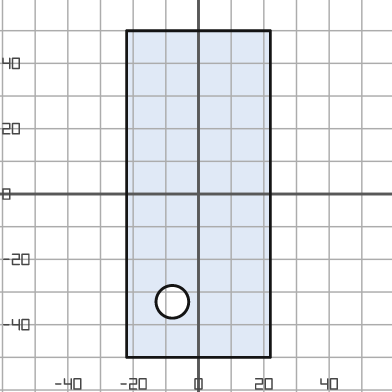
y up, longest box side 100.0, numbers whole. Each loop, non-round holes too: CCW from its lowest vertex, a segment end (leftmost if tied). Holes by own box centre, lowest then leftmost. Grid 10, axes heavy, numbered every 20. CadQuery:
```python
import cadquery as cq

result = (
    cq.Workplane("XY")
    .moveTo(-22.0, -50.0)
    .lineTo(22.0, -50.0)
    .lineTo(22.0, 50.0)
    .lineTo(-22.0, 50.0)
    .close()
    .moveTo(-8.0, -33.0)
    .circle(5.0)
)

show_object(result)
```